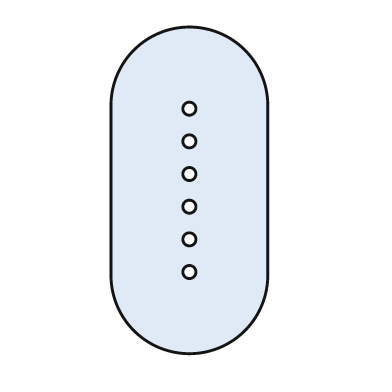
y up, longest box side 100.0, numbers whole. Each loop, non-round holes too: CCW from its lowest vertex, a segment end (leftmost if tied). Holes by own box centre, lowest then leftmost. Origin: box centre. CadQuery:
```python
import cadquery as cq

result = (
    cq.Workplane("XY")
    .moveTo(-24.0, -26.0)
    .threePointArc((0.0, -50.0), (24.0, -26.0))
    .lineTo(24.0, 26.0)
    .threePointArc((0.0, 50.0), (-24.0, 26.0))
    .close()
    .moveTo(0.0, -25.0)
    .circle(2.0)
    .moveTo(0.0, -15.0)
    .circle(2.0)
    .moveTo(0.0, -5.0)
    .circle(2.0)
    .moveTo(0.0, 5.0)
    .circle(2.0)
    .moveTo(0.0, 15.0)
    .circle(2.0)
    .moveTo(0.0, 25.0)
    .circle(2.0)
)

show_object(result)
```